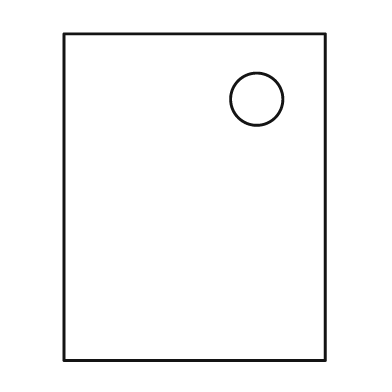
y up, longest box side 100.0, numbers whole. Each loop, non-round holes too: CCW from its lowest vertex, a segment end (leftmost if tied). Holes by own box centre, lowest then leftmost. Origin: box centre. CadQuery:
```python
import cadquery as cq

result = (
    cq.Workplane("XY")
    .moveTo(-40.0, -50.0)
    .lineTo(40.0, -50.0)
    .lineTo(40.0, 50.0)
    .lineTo(-40.0, 50.0)
    .close()
    .moveTo(19.0, 30.0)
    .circle(8.0)
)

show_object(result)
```